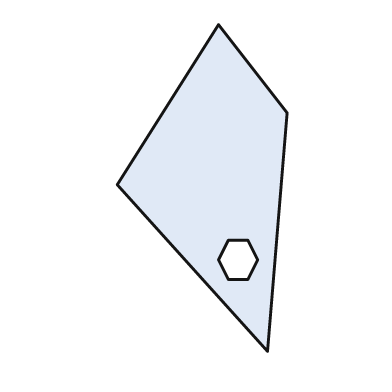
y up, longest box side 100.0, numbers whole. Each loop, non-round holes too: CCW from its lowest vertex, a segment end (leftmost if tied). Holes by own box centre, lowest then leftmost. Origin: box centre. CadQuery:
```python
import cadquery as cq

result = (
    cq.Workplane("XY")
    .moveTo(20.0, -50.0)
    .lineTo(26.0, 23.0)
    .lineTo(5.0, 50.0)
    .lineTo(-26.0, 1.0)
    .close()
    .moveTo(8.0, -28.0)
    .lineTo(14.0, -28.0)
    .lineTo(17.0, -22.0)
    .lineTo(14.0, -16.0)
    .lineTo(8.0, -16.0)
    .lineTo(5.0, -22.0)
    .close()
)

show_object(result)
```